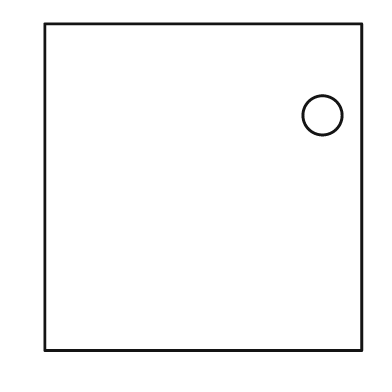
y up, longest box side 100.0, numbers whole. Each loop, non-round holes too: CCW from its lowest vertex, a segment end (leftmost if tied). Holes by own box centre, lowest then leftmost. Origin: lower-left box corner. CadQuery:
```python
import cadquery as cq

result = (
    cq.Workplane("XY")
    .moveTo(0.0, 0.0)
    .lineTo(97.0, 0.0)
    .lineTo(97.0, 100.0)
    .lineTo(0.0, 100.0)
    .close()
    .moveTo(85.0, 72.0)
    .circle(6.0)
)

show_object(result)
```